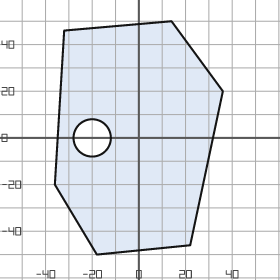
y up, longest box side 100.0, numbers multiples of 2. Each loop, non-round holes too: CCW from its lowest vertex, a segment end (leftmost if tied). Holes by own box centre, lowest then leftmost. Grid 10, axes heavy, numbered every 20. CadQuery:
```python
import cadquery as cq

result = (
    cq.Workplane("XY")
    .moveTo(-18.0, -50.0)
    .lineTo(22.0, -46.0)
    .lineTo(36.0, 20.0)
    .lineTo(14.0, 50.0)
    .lineTo(-32.0, 46.0)
    .lineTo(-36.0, -20.0)
    .close()
    .moveTo(-20.0, 0.0)
    .circle(8.0)
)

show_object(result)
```